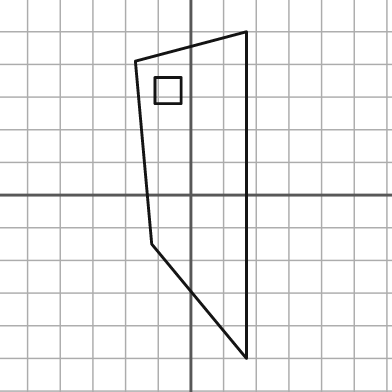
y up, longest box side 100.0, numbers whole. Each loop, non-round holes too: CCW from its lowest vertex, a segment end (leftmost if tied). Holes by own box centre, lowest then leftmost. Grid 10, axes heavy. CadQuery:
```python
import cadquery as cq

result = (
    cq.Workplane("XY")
    .moveTo(17.0, -50.0)
    .lineTo(17.0, 50.0)
    .lineTo(-17.0, 41.0)
    .lineTo(-12.0, -15.0)
    .close()
    .moveTo(-11.0, 28.0)
    .lineTo(-3.0, 28.0)
    .lineTo(-3.0, 36.0)
    .lineTo(-11.0, 36.0)
    .close()
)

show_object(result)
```